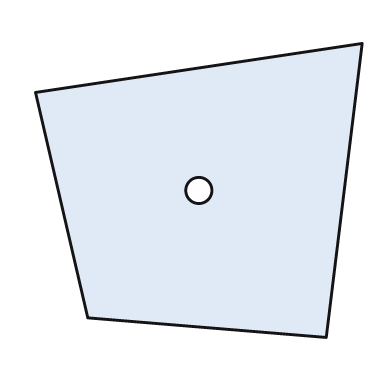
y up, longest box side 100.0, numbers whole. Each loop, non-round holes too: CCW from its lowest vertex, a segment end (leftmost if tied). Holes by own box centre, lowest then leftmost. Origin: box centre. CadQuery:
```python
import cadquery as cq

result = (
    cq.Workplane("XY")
    .moveTo(39.0, -45.0)
    .lineTo(50.0, 45.0)
    .lineTo(-50.0, 30.0)
    .lineTo(-34.0, -39.0)
    .close()
    .moveTo(0.0, 0.0)
    .circle(4.0)
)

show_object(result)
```